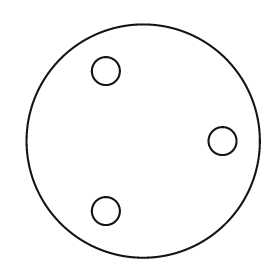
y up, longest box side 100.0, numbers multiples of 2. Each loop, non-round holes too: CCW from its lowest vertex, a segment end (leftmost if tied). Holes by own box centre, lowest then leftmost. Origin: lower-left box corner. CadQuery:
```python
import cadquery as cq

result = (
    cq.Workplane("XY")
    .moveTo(50.0, 50.0)
    .circle(50.0)
    .moveTo(34.0, 20.0)
    .circle(6.0)
    .moveTo(84.0, 50.0)
    .circle(6.0)
    .moveTo(34.0, 80.0)
    .circle(6.0)
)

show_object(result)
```